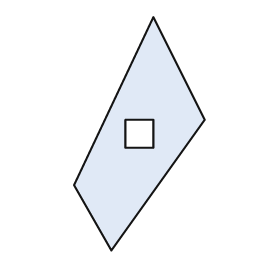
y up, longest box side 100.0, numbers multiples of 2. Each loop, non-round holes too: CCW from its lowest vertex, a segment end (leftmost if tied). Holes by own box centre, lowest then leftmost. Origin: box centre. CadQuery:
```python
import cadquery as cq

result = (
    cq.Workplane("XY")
    .moveTo(-12.0, -50.0)
    .lineTo(28.0, 6.0)
    .lineTo(6.0, 50.0)
    .lineTo(-28.0, -22.0)
    .close()
    .moveTo(-6.0, -6.0)
    .lineTo(6.0, -6.0)
    .lineTo(6.0, 6.0)
    .lineTo(-6.0, 6.0)
    .close()
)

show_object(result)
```